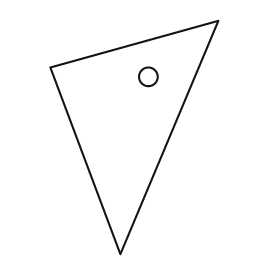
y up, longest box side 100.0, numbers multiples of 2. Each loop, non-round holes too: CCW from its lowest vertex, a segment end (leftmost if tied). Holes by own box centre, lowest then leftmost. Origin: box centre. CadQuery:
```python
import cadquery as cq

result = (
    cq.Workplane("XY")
    .moveTo(-6.0, -50.0)
    .lineTo(36.0, 50.0)
    .lineTo(-36.0, 30.0)
    .close()
    .moveTo(6.0, 26.0)
    .circle(4.0)
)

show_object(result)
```